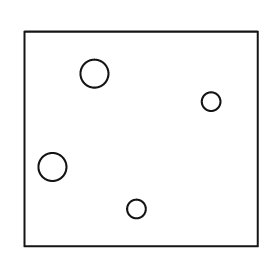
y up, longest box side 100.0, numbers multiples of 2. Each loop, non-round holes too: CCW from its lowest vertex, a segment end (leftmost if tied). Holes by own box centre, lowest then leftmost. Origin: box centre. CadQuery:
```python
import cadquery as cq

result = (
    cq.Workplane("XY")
    .moveTo(-50.0, -46.0)
    .lineTo(50.0, -46.0)
    .lineTo(50.0, 46.0)
    .lineTo(-50.0, 46.0)
    .close()
    .moveTo(-2.0, -30.0)
    .circle(4.0)
    .moveTo(-38.0, -12.0)
    .circle(6.0)
    .moveTo(30.0, 16.0)
    .circle(4.0)
    .moveTo(-20.0, 28.0)
    .circle(6.0)
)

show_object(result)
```